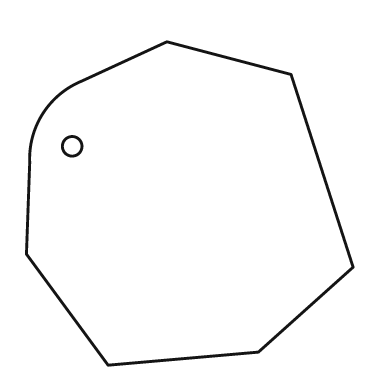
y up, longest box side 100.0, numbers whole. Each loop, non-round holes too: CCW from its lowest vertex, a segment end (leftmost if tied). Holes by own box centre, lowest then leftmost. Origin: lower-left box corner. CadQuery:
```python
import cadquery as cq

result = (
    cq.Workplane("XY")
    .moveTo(25.0, 0.0)
    .lineTo(71.0, 4.0)
    .lineTo(100.0, 30.0)
    .lineTo(81.0, 89.0)
    .lineTo(43.0, 99.0)
    .lineTo(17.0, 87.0)
    .threePointArc((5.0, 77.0), (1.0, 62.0))
    .lineTo(0.0, 34.0)
    .close()
    .moveTo(14.0, 67.0)
    .circle(3.0)
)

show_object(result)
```